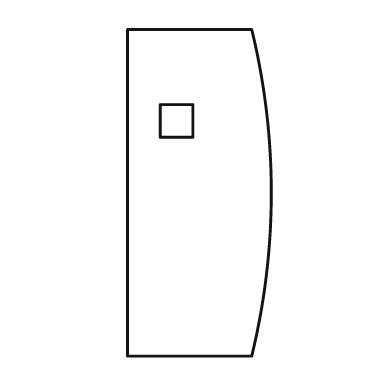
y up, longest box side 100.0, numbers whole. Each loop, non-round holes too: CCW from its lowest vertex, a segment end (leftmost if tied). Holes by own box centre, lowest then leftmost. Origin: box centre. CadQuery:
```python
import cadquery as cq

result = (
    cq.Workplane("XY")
    .moveTo(-22.0, -50.0)
    .lineTo(16.0, -50.0)
    .threePointArc((22.0, 0.0), (16.0, 50.0))
    .lineTo(-22.0, 50.0)
    .close()
    .moveTo(-12.0, 17.0)
    .lineTo(-2.0, 17.0)
    .lineTo(-2.0, 27.0)
    .lineTo(-12.0, 27.0)
    .close()
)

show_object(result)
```